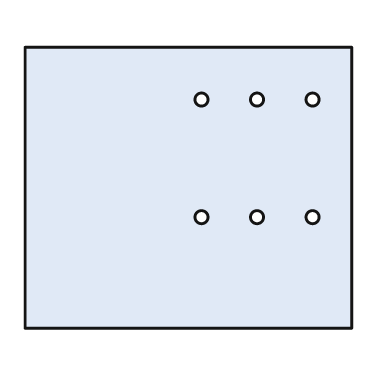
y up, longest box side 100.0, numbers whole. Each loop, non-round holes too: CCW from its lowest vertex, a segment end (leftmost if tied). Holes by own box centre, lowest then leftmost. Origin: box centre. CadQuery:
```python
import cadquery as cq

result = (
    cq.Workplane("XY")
    .moveTo(-50.0, -43.0)
    .lineTo(50.0, -43.0)
    .lineTo(50.0, 43.0)
    .lineTo(-50.0, 43.0)
    .close()
    .moveTo(4.0, -9.0)
    .circle(2.0)
    .moveTo(21.0, -9.0)
    .circle(2.0)
    .moveTo(38.0, -9.0)
    .circle(2.0)
    .moveTo(4.0, 27.0)
    .circle(2.0)
    .moveTo(21.0, 27.0)
    .circle(2.0)
    .moveTo(38.0, 27.0)
    .circle(2.0)
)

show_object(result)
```